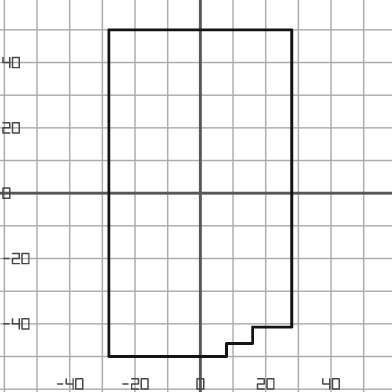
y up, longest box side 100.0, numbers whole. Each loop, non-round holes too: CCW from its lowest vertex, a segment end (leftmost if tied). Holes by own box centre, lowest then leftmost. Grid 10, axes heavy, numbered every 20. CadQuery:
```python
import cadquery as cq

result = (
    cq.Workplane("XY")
    .moveTo(-28.0, -50.0)
    .lineTo(8.0, -50.0)
    .lineTo(8.0, -46.0)
    .lineTo(16.0, -46.0)
    .lineTo(16.0, -41.0)
    .lineTo(28.0, -41.0)
    .lineTo(28.0, 50.0)
    .lineTo(-28.0, 50.0)
    .close()
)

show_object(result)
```